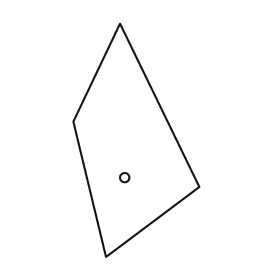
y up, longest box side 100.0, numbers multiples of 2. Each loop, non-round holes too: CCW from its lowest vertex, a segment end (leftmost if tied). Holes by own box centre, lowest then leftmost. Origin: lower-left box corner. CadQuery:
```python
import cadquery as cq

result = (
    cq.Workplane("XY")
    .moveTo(14.0, 0.0)
    .lineTo(54.0, 30.0)
    .lineTo(20.0, 100.0)
    .lineTo(0.0, 58.0)
    .close()
    .moveTo(22.0, 34.0)
    .circle(2.0)
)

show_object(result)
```